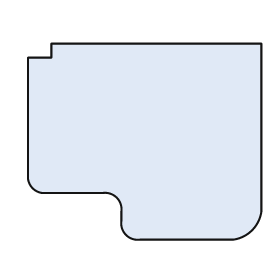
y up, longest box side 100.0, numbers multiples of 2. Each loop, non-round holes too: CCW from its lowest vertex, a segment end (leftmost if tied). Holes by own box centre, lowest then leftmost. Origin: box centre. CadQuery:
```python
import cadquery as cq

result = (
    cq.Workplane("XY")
    .moveTo(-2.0, -42.0)
    .lineTo(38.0, -42.0)
    .threePointArc((46.0, -38.0), (50.0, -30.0))
    .lineTo(50.0, 42.0)
    .lineTo(-40.0, 42.0)
    .lineTo(-40.0, 36.0)
    .lineTo(-50.0, 36.0)
    .lineTo(-50.0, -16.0)
    .threePointArc((-48.0, -20.0), (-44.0, -22.0))
    .lineTo(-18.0, -22.0)
    .threePointArc((-12.0, -24.0), (-10.0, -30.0))
    .lineTo(-10.0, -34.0)
    .threePointArc((-8.0, -40.0), (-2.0, -42.0))
    .close()
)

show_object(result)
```